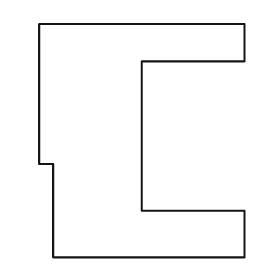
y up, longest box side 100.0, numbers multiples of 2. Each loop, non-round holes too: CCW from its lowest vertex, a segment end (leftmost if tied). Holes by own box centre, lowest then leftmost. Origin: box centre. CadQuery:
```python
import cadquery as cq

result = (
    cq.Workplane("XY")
    .moveTo(-38.0, -50.0)
    .lineTo(44.0, -50.0)
    .lineTo(44.0, -30.0)
    .lineTo(0.0, -30.0)
    .lineTo(0.0, 34.0)
    .lineTo(44.0, 34.0)
    .lineTo(44.0, 50.0)
    .lineTo(-44.0, 50.0)
    .lineTo(-44.0, -10.0)
    .lineTo(-38.0, -10.0)
    .close()
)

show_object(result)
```